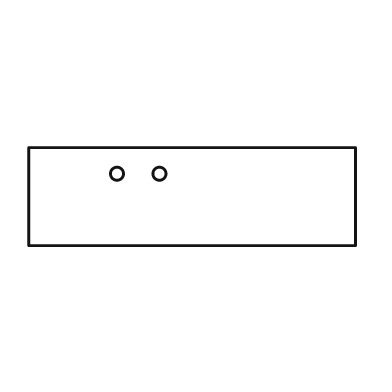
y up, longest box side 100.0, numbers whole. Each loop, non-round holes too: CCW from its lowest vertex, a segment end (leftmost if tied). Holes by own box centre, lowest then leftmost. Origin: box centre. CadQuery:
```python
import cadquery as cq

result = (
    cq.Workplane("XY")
    .moveTo(-50.0, -15.0)
    .lineTo(50.0, -15.0)
    .lineTo(50.0, 15.0)
    .lineTo(-50.0, 15.0)
    .close()
    .moveTo(-23.0, 7.0)
    .circle(2.0)
    .moveTo(-10.0, 7.0)
    .circle(2.0)
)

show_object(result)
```